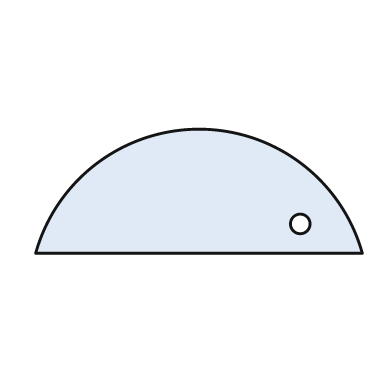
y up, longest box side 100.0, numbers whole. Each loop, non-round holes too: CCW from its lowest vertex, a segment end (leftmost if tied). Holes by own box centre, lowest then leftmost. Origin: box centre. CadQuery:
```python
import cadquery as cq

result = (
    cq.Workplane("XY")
    .moveTo(-50.0, -19.0)
    .lineTo(50.0, -19.0)
    .threePointArc((0.0, 19.0), (-50.0, -19.0))
    .close()
    .moveTo(31.0, -10.0)
    .circle(3.0)
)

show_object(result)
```